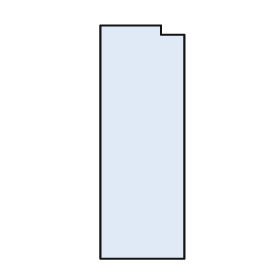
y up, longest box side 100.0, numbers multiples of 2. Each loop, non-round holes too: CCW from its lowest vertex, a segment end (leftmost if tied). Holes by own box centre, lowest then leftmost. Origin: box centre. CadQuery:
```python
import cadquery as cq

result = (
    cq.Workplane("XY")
    .moveTo(-18.0, -50.0)
    .lineTo(18.0, -50.0)
    .lineTo(18.0, 46.0)
    .lineTo(8.0, 46.0)
    .lineTo(8.0, 50.0)
    .lineTo(-18.0, 50.0)
    .close()
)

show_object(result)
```